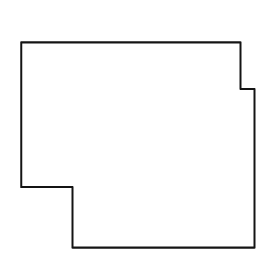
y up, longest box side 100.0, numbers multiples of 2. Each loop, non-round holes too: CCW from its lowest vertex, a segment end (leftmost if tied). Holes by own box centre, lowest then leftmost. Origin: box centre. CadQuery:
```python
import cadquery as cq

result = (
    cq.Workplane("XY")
    .moveTo(-28.0, -44.0)
    .lineTo(50.0, -44.0)
    .lineTo(50.0, 24.0)
    .lineTo(44.0, 24.0)
    .lineTo(44.0, 44.0)
    .lineTo(-50.0, 44.0)
    .lineTo(-50.0, -18.0)
    .lineTo(-28.0, -18.0)
    .close()
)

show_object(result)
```